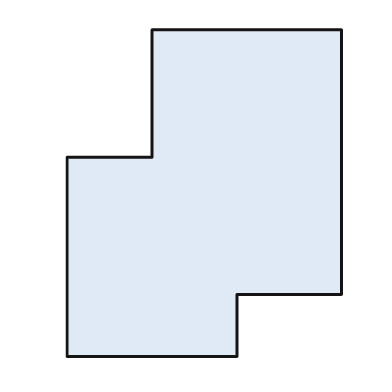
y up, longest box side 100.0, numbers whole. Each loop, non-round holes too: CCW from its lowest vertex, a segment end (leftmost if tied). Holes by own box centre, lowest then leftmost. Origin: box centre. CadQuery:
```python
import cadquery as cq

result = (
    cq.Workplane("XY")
    .moveTo(-42.0, -50.0)
    .lineTo(10.0, -50.0)
    .lineTo(10.0, -31.0)
    .lineTo(42.0, -31.0)
    .lineTo(42.0, 50.0)
    .lineTo(-16.0, 50.0)
    .lineTo(-16.0, 11.0)
    .lineTo(-42.0, 11.0)
    .close()
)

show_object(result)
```